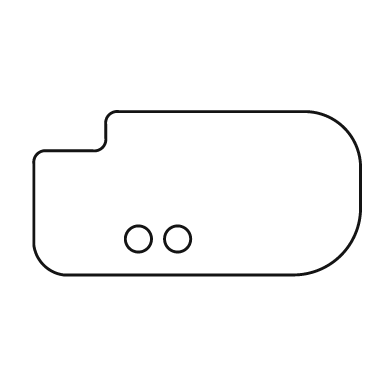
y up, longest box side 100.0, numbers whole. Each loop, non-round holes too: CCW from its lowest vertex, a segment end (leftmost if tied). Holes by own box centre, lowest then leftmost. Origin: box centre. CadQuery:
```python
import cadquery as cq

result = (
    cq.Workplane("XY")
    .moveTo(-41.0, -25.0)
    .lineTo(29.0, -25.0)
    .threePointArc((44.0, -19.0), (50.0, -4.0))
    .lineTo(50.0, 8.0)
    .threePointArc((45.0, 20.0), (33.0, 25.0))
    .lineTo(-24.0, 25.0)
    .threePointArc((-27.0, 24.0), (-28.0, 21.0))
    .lineTo(-28.0, 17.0)
    .threePointArc((-29.0, 14.0), (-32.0, 13.0))
    .lineTo(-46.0, 13.0)
    .threePointArc((-49.0, 12.0), (-50.0, 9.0))
    .lineTo(-50.0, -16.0)
    .threePointArc((-47.0, -22.0), (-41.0, -25.0))
    .close()
    .moveTo(-18.0, -14.0)
    .circle(4.0)
    .moveTo(-6.0, -14.0)
    .circle(4.0)
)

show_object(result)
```